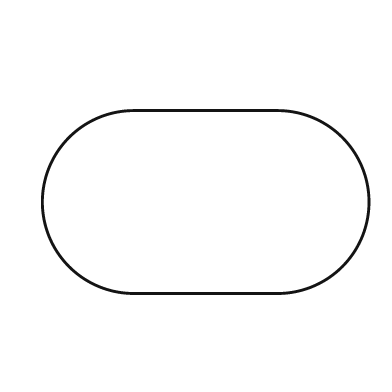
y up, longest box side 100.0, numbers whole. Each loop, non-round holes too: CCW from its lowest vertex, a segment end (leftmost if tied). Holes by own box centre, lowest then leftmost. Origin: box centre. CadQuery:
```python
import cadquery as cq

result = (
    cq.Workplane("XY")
    .moveTo(-22.0, -28.0)
    .lineTo(22.0, -28.0)
    .threePointArc((50.0, 0.0), (22.0, 28.0))
    .lineTo(-22.0, 28.0)
    .threePointArc((-50.0, 0.0), (-22.0, -28.0))
    .close()
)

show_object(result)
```